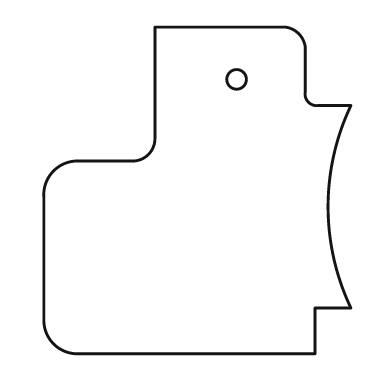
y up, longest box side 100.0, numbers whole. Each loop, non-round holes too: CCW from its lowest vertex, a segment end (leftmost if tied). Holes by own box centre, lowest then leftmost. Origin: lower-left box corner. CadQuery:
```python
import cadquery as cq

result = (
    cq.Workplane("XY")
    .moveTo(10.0, 0.0)
    .lineTo(83.0, 0.0)
    .lineTo(83.0, 14.0)
    .lineTo(94.0, 14.0)
    .threePointArc((87.0, 45.0), (94.0, 76.0))
    .lineTo(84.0, 76.0)
    .threePointArc((81.0, 77.0), (80.0, 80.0))
    .lineTo(80.0, 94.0)
    .threePointArc((78.0, 98.0), (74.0, 100.0))
    .lineTo(34.0, 100.0)
    .lineTo(34.0, 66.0)
    .threePointArc((32.0, 61.0), (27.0, 59.0))
    .lineTo(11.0, 59.0)
    .threePointArc((3.0, 56.0), (0.0, 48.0))
    .lineTo(0.0, 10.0)
    .threePointArc((3.0, 3.0), (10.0, 0.0))
    .close()
    .moveTo(59.0, 84.0)
    .circle(3.0)
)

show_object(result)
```